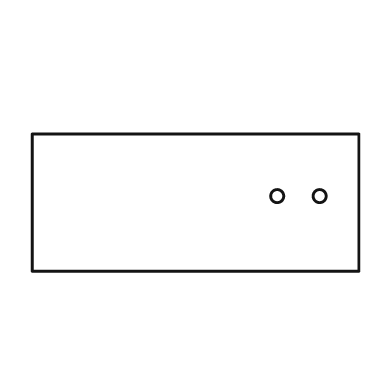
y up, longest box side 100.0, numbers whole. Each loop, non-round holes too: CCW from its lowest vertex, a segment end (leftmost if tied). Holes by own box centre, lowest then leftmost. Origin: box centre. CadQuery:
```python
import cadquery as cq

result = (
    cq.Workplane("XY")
    .moveTo(-50.0, -21.0)
    .lineTo(50.0, -21.0)
    .lineTo(50.0, 21.0)
    .lineTo(-50.0, 21.0)
    .close()
    .moveTo(25.0, 2.0)
    .circle(2.0)
    .moveTo(38.0, 2.0)
    .circle(2.0)
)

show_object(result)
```